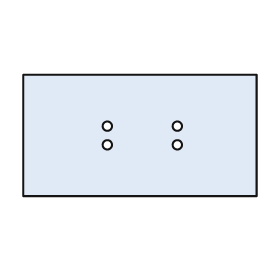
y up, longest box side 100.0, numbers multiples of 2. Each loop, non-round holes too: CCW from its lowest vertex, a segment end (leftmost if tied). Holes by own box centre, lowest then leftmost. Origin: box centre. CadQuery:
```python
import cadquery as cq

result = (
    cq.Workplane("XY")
    .moveTo(-50.0, -26.0)
    .lineTo(50.0, -26.0)
    .lineTo(50.0, 26.0)
    .lineTo(-50.0, 26.0)
    .close()
    .moveTo(-14.0, -4.0)
    .circle(2.0)
    .moveTo(16.0, -4.0)
    .circle(2.0)
    .moveTo(-14.0, 4.0)
    .circle(2.0)
    .moveTo(16.0, 4.0)
    .circle(2.0)
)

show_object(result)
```